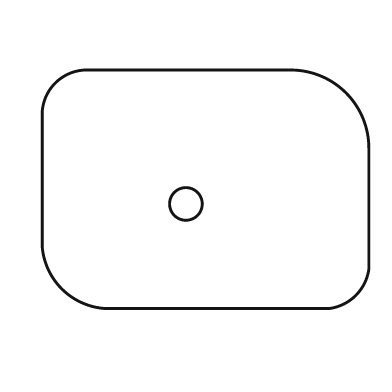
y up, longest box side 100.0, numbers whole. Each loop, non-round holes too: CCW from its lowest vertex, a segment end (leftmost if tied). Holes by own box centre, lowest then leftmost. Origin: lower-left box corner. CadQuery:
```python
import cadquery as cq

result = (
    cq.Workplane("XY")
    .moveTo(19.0, 0.0)
    .lineTo(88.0, 0.0)
    .threePointArc((96.0, 4.0), (100.0, 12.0))
    .lineTo(100.0, 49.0)
    .threePointArc((93.0, 66.0), (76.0, 73.0))
    .lineTo(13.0, 73.0)
    .threePointArc((4.0, 69.0), (0.0, 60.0))
    .lineTo(0.0, 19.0)
    .threePointArc((6.0, 6.0), (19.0, 0.0))
    .close()
    .moveTo(44.0, 32.0)
    .circle(5.0)
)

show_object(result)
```